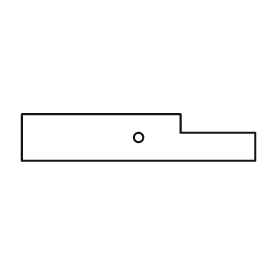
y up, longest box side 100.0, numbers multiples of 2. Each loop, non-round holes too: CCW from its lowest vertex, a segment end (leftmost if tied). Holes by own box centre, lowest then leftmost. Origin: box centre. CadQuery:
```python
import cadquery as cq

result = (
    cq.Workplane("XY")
    .moveTo(-50.0, -10.0)
    .lineTo(50.0, -10.0)
    .lineTo(50.0, 2.0)
    .lineTo(18.0, 2.0)
    .lineTo(18.0, 10.0)
    .lineTo(-50.0, 10.0)
    .close()
    .moveTo(0.0, 0.0)
    .circle(2.0)
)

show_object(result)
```